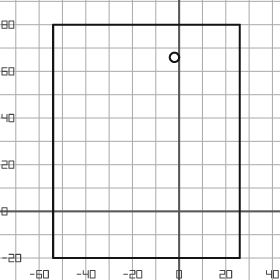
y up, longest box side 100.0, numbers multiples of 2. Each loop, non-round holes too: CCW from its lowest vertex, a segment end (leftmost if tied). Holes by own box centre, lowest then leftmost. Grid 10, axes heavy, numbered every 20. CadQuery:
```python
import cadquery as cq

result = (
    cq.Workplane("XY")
    .moveTo(-54.0, -20.0)
    .lineTo(26.0, -20.0)
    .lineTo(26.0, 80.0)
    .lineTo(-54.0, 80.0)
    .close()
    .moveTo(-2.0, 66.0)
    .circle(2.0)
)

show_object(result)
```